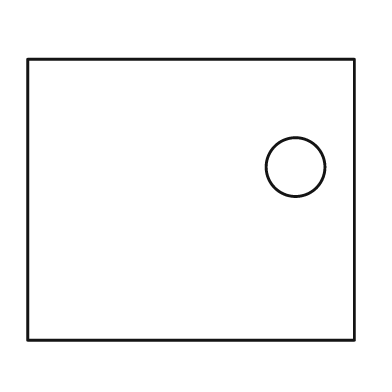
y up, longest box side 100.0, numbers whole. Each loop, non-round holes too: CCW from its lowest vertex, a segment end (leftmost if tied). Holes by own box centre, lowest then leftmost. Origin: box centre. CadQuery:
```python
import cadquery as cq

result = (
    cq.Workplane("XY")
    .moveTo(-50.0, -43.0)
    .lineTo(50.0, -43.0)
    .lineTo(50.0, 43.0)
    .lineTo(-50.0, 43.0)
    .close()
    .moveTo(32.0, 10.0)
    .circle(9.0)
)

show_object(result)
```